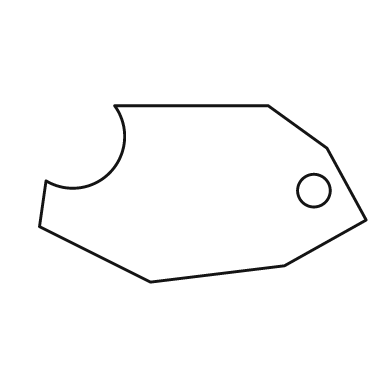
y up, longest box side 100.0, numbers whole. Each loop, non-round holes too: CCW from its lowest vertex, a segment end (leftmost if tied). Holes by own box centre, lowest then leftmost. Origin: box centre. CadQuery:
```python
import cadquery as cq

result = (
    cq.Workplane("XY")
    .moveTo(-16.0, -27.0)
    .lineTo(25.0, -22.0)
    .lineTo(50.0, -8.0)
    .lineTo(38.0, 14.0)
    .lineTo(20.0, 27.0)
    .lineTo(-27.0, 27.0)
    .threePointArc((-28.0, 7.0), (-48.0, 4.0))
    .lineTo(-50.0, -10.0)
    .close()
    .moveTo(34.0, 1.0)
    .circle(5.0)
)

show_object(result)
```